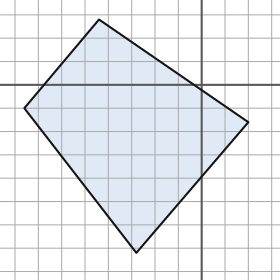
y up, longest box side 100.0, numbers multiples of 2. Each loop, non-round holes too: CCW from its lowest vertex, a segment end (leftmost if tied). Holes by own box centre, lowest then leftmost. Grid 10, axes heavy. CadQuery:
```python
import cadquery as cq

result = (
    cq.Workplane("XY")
    .moveTo(-28.0, -72.0)
    .lineTo(20.0, -16.0)
    .lineTo(-44.0, 28.0)
    .lineTo(-76.0, -10.0)
    .close()
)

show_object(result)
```